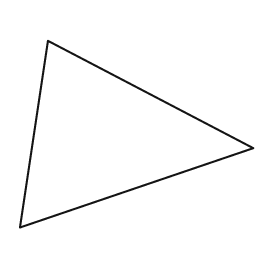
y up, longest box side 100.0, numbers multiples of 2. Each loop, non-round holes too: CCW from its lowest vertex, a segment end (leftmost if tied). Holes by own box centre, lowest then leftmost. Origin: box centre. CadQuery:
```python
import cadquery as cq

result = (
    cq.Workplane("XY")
    .moveTo(-50.0, -40.0)
    .lineTo(50.0, -6.0)
    .lineTo(-38.0, 40.0)
    .close()
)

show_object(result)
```